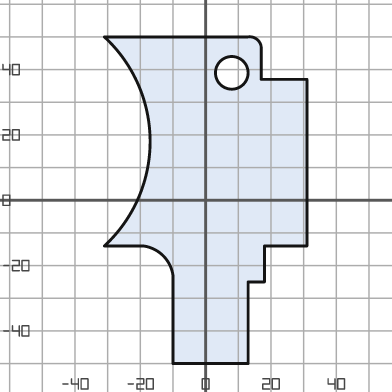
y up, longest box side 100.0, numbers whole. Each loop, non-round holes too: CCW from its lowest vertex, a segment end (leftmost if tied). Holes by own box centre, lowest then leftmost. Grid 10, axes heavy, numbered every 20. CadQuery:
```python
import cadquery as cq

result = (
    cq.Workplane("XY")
    .moveTo(-10.0, -50.0)
    .lineTo(13.0, -50.0)
    .lineTo(13.0, -25.0)
    .lineTo(18.0, -25.0)
    .lineTo(18.0, -14.0)
    .lineTo(31.0, -14.0)
    .lineTo(31.0, 37.0)
    .lineTo(17.0, 37.0)
    .lineTo(17.0, 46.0)
    .threePointArc((16.0, 49.0), (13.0, 50.0))
    .lineTo(-31.0, 50.0)
    .threePointArc((-17.0, 18.0), (-31.0, -14.0))
    .lineTo(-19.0, -14.0)
    .threePointArc((-13.0, -17.0), (-10.0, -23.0))
    .close()
    .moveTo(8.0, 39.0)
    .circle(5.0)
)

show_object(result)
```